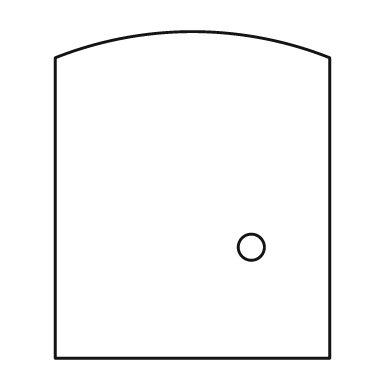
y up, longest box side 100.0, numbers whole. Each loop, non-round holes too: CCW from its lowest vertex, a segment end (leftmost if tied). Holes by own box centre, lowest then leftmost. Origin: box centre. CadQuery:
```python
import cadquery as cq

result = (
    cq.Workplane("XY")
    .moveTo(-42.0, -50.0)
    .lineTo(42.0, -50.0)
    .lineTo(42.0, 42.0)
    .threePointArc((0.0, 50.0), (-42.0, 42.0))
    .close()
    .moveTo(18.0, -16.0)
    .circle(4.0)
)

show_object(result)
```